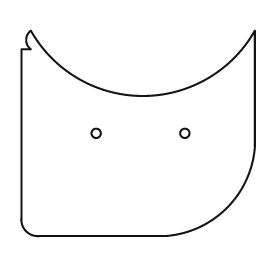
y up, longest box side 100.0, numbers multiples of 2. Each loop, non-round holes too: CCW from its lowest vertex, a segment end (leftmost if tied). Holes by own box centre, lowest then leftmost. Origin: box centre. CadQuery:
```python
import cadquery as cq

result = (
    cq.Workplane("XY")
    .moveTo(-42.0, -44.0)
    .lineTo(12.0, -44.0)
    .threePointArc((38.0, -32.0), (50.0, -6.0))
    .lineTo(50.0, 44.0)
    .threePointArc((2.0, 16.0), (-46.0, 44.0))
    .threePointArc((-48.0, 40.0), (-46.0, 36.0))
    .lineTo(-50.0, 36.0)
    .lineTo(-50.0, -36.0)
    .threePointArc((-48.0, -42.0), (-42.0, -44.0))
    .close()
    .moveTo(-18.0, 0.0)
    .circle(2.0)
    .moveTo(20.0, 0.0)
    .circle(2.0)
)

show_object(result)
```